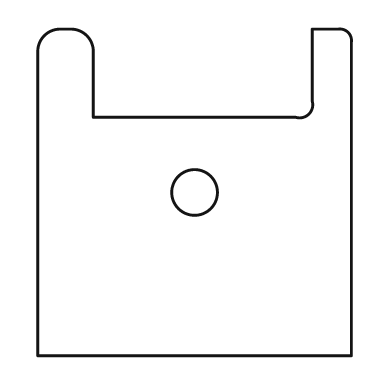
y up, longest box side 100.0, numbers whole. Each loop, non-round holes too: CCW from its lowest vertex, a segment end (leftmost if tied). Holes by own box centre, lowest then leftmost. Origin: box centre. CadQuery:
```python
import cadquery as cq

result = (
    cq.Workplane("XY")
    .moveTo(-48.0, -50.0)
    .lineTo(48.0, -50.0)
    .lineTo(48.0, 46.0)
    .threePointArc((47.0, 49.0), (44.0, 50.0))
    .lineTo(36.0, 50.0)
    .lineTo(36.0, 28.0)
    .threePointArc((35.0, 24.0), (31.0, 23.0))
    .lineTo(-31.0, 23.0)
    .lineTo(-31.0, 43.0)
    .threePointArc((-33.0, 48.0), (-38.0, 50.0))
    .lineTo(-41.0, 50.0)
    .threePointArc((-46.0, 48.0), (-48.0, 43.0))
    .close()
    .moveTo(0.0, 0.0)
    .circle(7.0)
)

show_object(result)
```